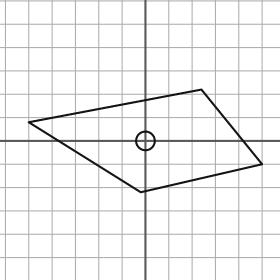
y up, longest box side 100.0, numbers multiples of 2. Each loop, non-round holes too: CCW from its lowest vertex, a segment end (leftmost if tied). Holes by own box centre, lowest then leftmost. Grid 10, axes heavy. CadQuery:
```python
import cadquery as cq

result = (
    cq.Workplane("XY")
    .moveTo(-2.0, -22.0)
    .lineTo(50.0, -10.0)
    .lineTo(24.0, 22.0)
    .lineTo(-50.0, 8.0)
    .close()
    .moveTo(0.0, 0.0)
    .circle(4.0)
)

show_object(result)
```